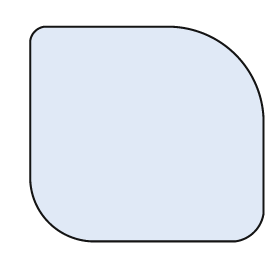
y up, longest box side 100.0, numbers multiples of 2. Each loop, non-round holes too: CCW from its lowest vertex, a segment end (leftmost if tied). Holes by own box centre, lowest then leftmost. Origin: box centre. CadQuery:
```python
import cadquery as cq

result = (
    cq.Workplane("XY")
    .moveTo(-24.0, -46.0)
    .lineTo(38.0, -46.0)
    .threePointArc((46.0, -42.0), (50.0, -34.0))
    .lineTo(50.0, 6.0)
    .threePointArc((38.0, 34.0), (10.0, 46.0))
    .lineTo(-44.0, 46.0)
    .threePointArc((-48.0, 44.0), (-50.0, 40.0))
    .lineTo(-50.0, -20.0)
    .threePointArc((-42.0, -38.0), (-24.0, -46.0))
    .close()
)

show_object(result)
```